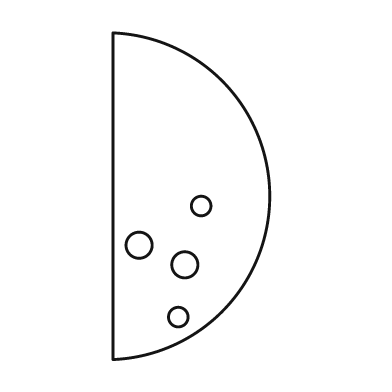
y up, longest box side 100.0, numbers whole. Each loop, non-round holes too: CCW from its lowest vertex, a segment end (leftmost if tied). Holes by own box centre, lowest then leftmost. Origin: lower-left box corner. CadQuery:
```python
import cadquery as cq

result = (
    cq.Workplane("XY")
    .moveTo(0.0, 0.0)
    .threePointArc((48.0, 50.0), (0.0, 100.0))
    .close()
    .moveTo(20.0, 13.0)
    .circle(3.0)
    .moveTo(22.0, 29.0)
    .circle(4.0)
    .moveTo(8.0, 35.0)
    .circle(4.0)
    .moveTo(27.0, 47.0)
    .circle(3.0)
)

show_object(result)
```